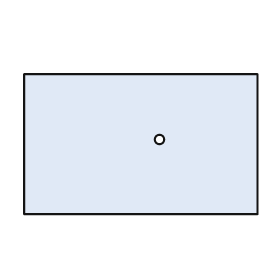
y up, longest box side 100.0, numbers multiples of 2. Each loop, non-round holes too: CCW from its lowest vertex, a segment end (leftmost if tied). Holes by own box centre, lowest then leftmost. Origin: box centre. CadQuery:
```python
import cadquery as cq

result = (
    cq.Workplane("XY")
    .moveTo(-50.0, -30.0)
    .lineTo(50.0, -30.0)
    .lineTo(50.0, 30.0)
    .lineTo(-50.0, 30.0)
    .close()
    .moveTo(8.0, 2.0)
    .circle(2.0)
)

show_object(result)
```